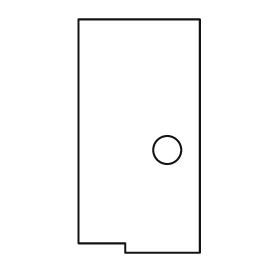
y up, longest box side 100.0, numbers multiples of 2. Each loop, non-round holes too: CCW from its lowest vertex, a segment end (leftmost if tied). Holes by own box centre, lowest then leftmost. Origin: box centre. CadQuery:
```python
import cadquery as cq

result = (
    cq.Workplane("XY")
    .moveTo(-6.0, -50.0)
    .lineTo(26.0, -50.0)
    .lineTo(26.0, 50.0)
    .lineTo(-26.0, 50.0)
    .lineTo(-26.0, -46.0)
    .lineTo(-6.0, -46.0)
    .close()
    .moveTo(12.0, -6.0)
    .circle(6.0)
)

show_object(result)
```